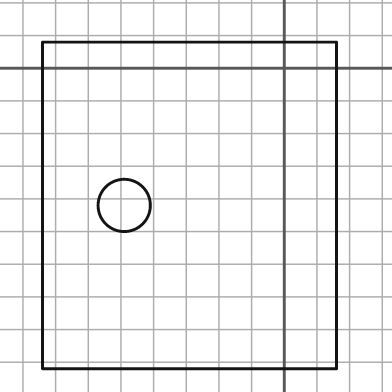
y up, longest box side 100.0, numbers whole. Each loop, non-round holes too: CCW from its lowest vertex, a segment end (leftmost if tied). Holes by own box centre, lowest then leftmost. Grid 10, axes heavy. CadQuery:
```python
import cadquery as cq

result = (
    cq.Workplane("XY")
    .moveTo(-74.0, -92.0)
    .lineTo(16.0, -92.0)
    .lineTo(16.0, 8.0)
    .lineTo(-74.0, 8.0)
    .close()
    .moveTo(-49.0, -42.0)
    .circle(8.0)
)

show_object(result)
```